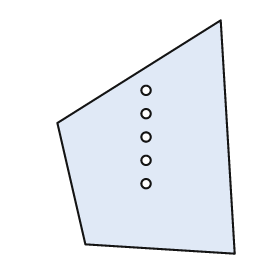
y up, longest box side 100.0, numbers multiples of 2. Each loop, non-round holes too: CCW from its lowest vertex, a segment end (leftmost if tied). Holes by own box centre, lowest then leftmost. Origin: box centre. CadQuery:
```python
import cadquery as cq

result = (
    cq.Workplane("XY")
    .moveTo(38.0, -50.0)
    .lineTo(32.0, 50.0)
    .lineTo(-38.0, 6.0)
    .lineTo(-26.0, -46.0)
    .close()
    .moveTo(0.0, -20.0)
    .circle(2.0)
    .moveTo(0.0, -10.0)
    .circle(2.0)
    .moveTo(0.0, 0.0)
    .circle(2.0)
    .moveTo(0.0, 10.0)
    .circle(2.0)
    .moveTo(0.0, 20.0)
    .circle(2.0)
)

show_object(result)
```